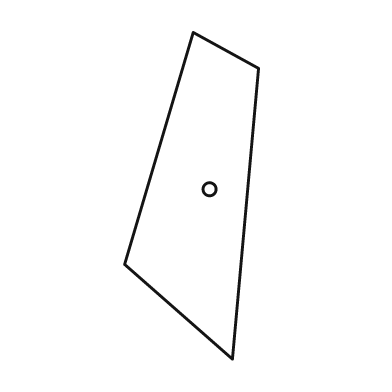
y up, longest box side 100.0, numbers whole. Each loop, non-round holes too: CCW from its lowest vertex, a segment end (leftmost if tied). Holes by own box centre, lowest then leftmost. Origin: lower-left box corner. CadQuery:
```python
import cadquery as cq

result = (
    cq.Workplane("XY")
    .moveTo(33.0, 0.0)
    .lineTo(41.0, 89.0)
    .lineTo(21.0, 100.0)
    .lineTo(0.0, 29.0)
    .close()
    .moveTo(26.0, 52.0)
    .circle(2.0)
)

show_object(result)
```